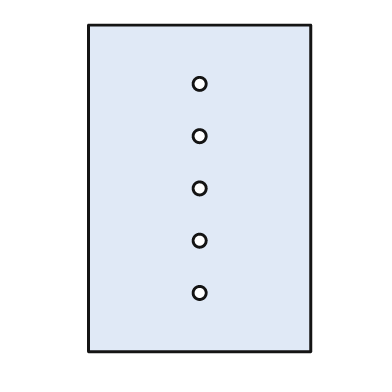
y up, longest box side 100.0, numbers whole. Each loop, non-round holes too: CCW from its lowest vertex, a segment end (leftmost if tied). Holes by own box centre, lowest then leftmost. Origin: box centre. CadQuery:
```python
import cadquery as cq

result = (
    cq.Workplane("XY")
    .moveTo(-34.0, -50.0)
    .lineTo(34.0, -50.0)
    .lineTo(34.0, 50.0)
    .lineTo(-34.0, 50.0)
    .close()
    .moveTo(0.0, -32.0)
    .circle(2.0)
    .moveTo(0.0, -16.0)
    .circle(2.0)
    .moveTo(0.0, 0.0)
    .circle(2.0)
    .moveTo(0.0, 16.0)
    .circle(2.0)
    .moveTo(0.0, 32.0)
    .circle(2.0)
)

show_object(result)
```